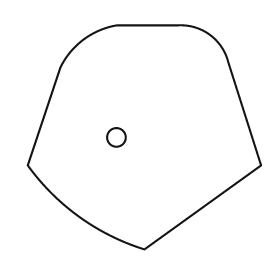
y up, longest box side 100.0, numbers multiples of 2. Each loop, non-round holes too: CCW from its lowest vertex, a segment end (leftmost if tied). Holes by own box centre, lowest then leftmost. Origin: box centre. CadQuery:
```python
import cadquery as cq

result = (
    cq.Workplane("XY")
    .moveTo(0.0, -48.0)
    .lineTo(50.0, -12.0)
    .lineTo(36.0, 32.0)
    .threePointArc((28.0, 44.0), (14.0, 48.0))
    .lineTo(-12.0, 48.0)
    .threePointArc((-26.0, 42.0), (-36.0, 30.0))
    .lineTo(-50.0, -12.0)
    .threePointArc((-28.0, -34.0), (0.0, -48.0))
    .close()
    .moveTo(-12.0, 0.0)
    .circle(4.0)
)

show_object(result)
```